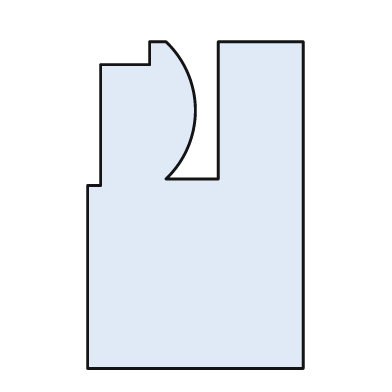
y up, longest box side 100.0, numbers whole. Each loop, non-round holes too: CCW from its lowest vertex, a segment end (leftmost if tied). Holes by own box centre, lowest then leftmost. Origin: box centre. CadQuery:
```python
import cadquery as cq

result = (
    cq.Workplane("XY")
    .moveTo(-33.0, -50.0)
    .lineTo(33.0, -50.0)
    .lineTo(33.0, 50.0)
    .lineTo(7.0, 50.0)
    .lineTo(7.0, 8.0)
    .lineTo(-9.0, 8.0)
    .threePointArc((0.0, 29.0), (-9.0, 50.0))
    .lineTo(-14.0, 50.0)
    .lineTo(-14.0, 43.0)
    .lineTo(-29.0, 43.0)
    .lineTo(-29.0, 6.0)
    .lineTo(-33.0, 6.0)
    .close()
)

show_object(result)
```